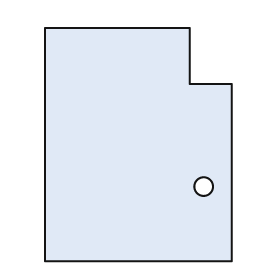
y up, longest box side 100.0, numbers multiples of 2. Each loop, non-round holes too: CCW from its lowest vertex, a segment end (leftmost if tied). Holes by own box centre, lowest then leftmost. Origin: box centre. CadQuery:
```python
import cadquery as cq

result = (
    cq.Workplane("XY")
    .moveTo(-40.0, -50.0)
    .lineTo(40.0, -50.0)
    .lineTo(40.0, 26.0)
    .lineTo(22.0, 26.0)
    .lineTo(22.0, 50.0)
    .lineTo(-40.0, 50.0)
    .close()
    .moveTo(28.0, -18.0)
    .circle(4.0)
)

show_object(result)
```